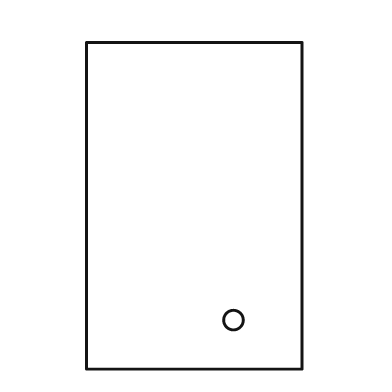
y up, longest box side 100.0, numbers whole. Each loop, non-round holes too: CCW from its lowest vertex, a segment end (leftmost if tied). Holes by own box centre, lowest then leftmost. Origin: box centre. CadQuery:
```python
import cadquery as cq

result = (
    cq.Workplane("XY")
    .moveTo(-33.0, -50.0)
    .lineTo(33.0, -50.0)
    .lineTo(33.0, 50.0)
    .lineTo(-33.0, 50.0)
    .close()
    .moveTo(12.0, -35.0)
    .circle(3.0)
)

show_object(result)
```